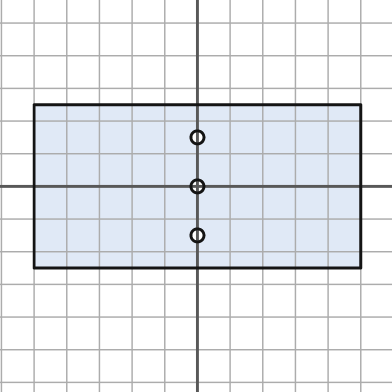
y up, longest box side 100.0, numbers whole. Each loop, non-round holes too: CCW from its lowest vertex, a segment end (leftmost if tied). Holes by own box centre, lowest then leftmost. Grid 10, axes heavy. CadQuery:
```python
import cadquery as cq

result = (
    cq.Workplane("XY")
    .moveTo(-50.0, -25.0)
    .lineTo(50.0, -25.0)
    .lineTo(50.0, 25.0)
    .lineTo(-50.0, 25.0)
    .close()
    .moveTo(0.0, -15.0)
    .circle(2.0)
    .moveTo(0.0, 0.0)
    .circle(2.0)
    .moveTo(0.0, 15.0)
    .circle(2.0)
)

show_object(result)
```